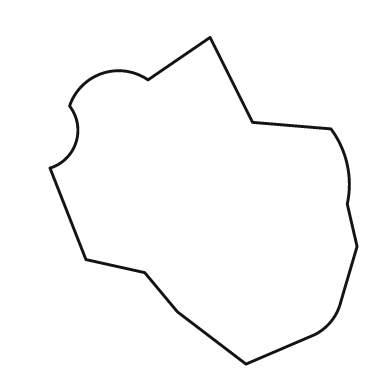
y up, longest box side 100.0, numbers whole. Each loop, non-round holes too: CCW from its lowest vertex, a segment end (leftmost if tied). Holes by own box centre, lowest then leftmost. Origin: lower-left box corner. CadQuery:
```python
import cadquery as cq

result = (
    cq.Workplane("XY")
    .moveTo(60.0, 0.0)
    .lineTo(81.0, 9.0)
    .threePointArc((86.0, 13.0), (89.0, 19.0))
    .lineTo(94.0, 36.0)
    .lineTo(91.0, 49.0)
    .threePointArc((91.0, 61.0), (86.0, 72.0))
    .lineTo(62.0, 74.0)
    .lineTo(49.0, 100.0)
    .lineTo(30.0, 87.0)
    .threePointArc((16.0, 89.0), (6.0, 79.0))
    .threePointArc((8.0, 68.0), (0.0, 60.0))
    .lineTo(11.0, 32.0)
    .lineTo(29.0, 28.0)
    .lineTo(39.0, 16.0)
    .close()
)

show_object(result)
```